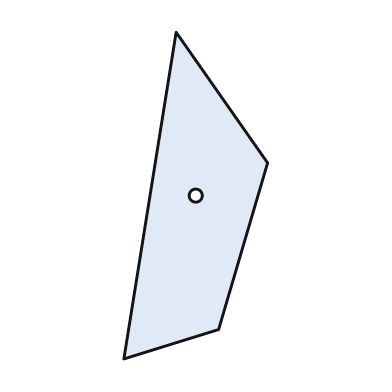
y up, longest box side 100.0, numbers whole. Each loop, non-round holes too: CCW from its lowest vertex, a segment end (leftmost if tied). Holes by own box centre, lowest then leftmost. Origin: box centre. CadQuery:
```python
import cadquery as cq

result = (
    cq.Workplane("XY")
    .moveTo(-22.0, -50.0)
    .lineTo(7.0, -41.0)
    .lineTo(22.0, 10.0)
    .lineTo(-6.0, 50.0)
    .close()
    .moveTo(0.0, 0.0)
    .circle(2.0)
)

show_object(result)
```